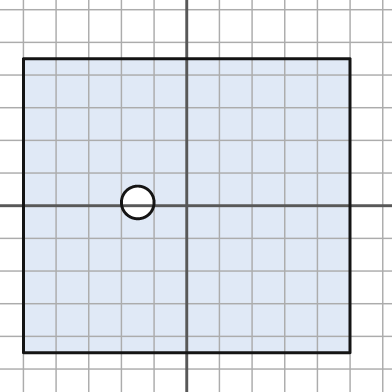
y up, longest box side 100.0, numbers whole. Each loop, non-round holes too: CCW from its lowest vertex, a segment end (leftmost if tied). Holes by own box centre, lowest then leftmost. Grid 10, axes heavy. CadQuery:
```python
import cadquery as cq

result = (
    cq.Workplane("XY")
    .moveTo(-50.0, -45.0)
    .lineTo(50.0, -45.0)
    .lineTo(50.0, 45.0)
    .lineTo(-50.0, 45.0)
    .close()
    .moveTo(-15.0, 1.0)
    .circle(5.0)
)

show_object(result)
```